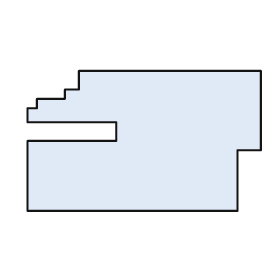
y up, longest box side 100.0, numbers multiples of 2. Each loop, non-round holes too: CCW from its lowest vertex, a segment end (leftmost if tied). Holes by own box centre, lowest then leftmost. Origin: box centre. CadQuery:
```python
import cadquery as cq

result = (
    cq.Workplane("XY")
    .moveTo(-50.0, -30.0)
    .lineTo(40.0, -30.0)
    .lineTo(40.0, -4.0)
    .lineTo(50.0, -4.0)
    .lineTo(50.0, 30.0)
    .lineTo(-28.0, 30.0)
    .lineTo(-28.0, 22.0)
    .lineTo(-34.0, 22.0)
    .lineTo(-34.0, 18.0)
    .lineTo(-46.0, 18.0)
    .lineTo(-46.0, 14.0)
    .lineTo(-50.0, 14.0)
    .lineTo(-50.0, 8.0)
    .lineTo(-12.0, 8.0)
    .lineTo(-12.0, 0.0)
    .lineTo(-50.0, 0.0)
    .close()
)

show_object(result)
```